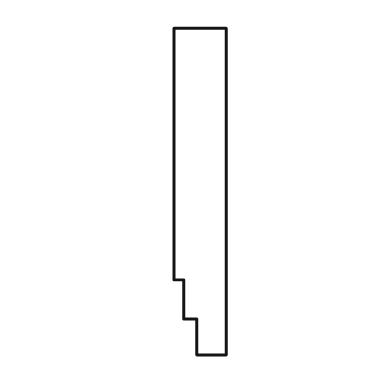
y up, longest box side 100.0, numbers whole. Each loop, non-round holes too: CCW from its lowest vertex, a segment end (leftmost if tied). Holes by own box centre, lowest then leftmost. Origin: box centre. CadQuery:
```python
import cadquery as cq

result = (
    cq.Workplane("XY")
    .moveTo(-1.0, -50.0)
    .lineTo(8.0, -50.0)
    .lineTo(8.0, 50.0)
    .lineTo(-8.0, 50.0)
    .lineTo(-8.0, -27.0)
    .lineTo(-5.0, -27.0)
    .lineTo(-5.0, -39.0)
    .lineTo(-1.0, -39.0)
    .close()
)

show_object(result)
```